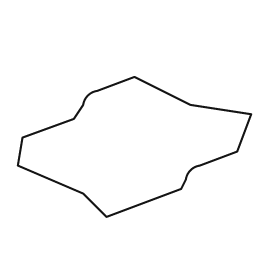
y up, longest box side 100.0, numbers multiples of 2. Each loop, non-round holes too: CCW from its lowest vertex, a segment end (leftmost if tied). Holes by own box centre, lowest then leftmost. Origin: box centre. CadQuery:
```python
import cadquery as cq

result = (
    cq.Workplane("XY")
    .moveTo(-12.0, -30.0)
    .lineTo(20.0, -18.0)
    .lineTo(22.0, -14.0)
    .threePointArc((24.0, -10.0), (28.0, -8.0))
    .lineTo(44.0, -2.0)
    .lineTo(50.0, 14.0)
    .lineTo(24.0, 18.0)
    .lineTo(0.0, 30.0)
    .lineTo(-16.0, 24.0)
    .threePointArc((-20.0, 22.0), (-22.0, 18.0))
    .lineTo(-26.0, 12.0)
    .lineTo(-48.0, 4.0)
    .lineTo(-50.0, -8.0)
    .lineTo(-22.0, -20.0)
    .close()
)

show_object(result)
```